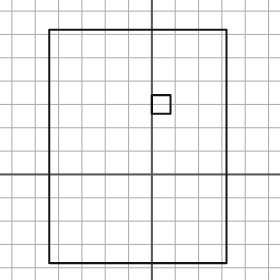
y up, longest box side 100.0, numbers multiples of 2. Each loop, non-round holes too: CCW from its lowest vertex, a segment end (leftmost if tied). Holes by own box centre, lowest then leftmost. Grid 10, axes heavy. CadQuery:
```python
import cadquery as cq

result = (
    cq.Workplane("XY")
    .moveTo(-44.0, -38.0)
    .lineTo(32.0, -38.0)
    .lineTo(32.0, 62.0)
    .lineTo(-44.0, 62.0)
    .close()
    .moveTo(0.0, 26.0)
    .lineTo(8.0, 26.0)
    .lineTo(8.0, 34.0)
    .lineTo(0.0, 34.0)
    .close()
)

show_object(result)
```